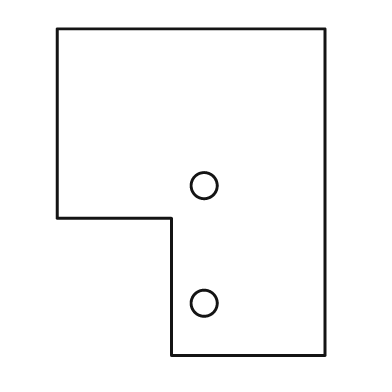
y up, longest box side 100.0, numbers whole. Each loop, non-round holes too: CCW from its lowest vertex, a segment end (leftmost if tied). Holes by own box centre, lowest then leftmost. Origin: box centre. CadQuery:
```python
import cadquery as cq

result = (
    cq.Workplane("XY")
    .moveTo(-6.0, -50.0)
    .lineTo(41.0, -50.0)
    .lineTo(41.0, 50.0)
    .lineTo(-41.0, 50.0)
    .lineTo(-41.0, -8.0)
    .lineTo(-6.0, -8.0)
    .close()
    .moveTo(4.0, -34.0)
    .circle(4.0)
    .moveTo(4.0, 2.0)
    .circle(4.0)
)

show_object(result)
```